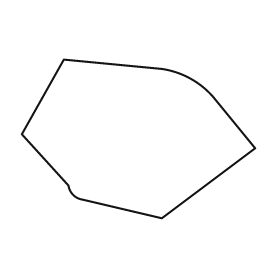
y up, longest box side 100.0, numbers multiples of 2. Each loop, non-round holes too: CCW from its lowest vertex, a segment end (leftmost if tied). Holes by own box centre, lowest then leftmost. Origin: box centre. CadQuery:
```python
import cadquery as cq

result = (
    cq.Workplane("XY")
    .moveTo(10.0, -34.0)
    .lineTo(50.0, -4.0)
    .lineTo(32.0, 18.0)
    .threePointArc((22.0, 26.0), (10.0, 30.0))
    .lineTo(-32.0, 34.0)
    .lineTo(-50.0, 2.0)
    .lineTo(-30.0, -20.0)
    .threePointArc((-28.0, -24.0), (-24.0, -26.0))
    .close()
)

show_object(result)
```